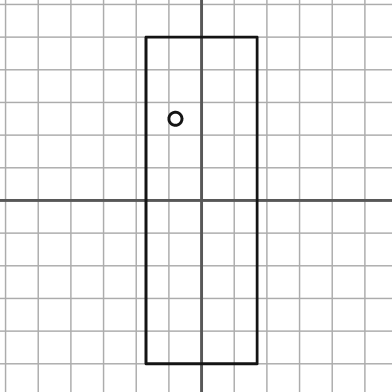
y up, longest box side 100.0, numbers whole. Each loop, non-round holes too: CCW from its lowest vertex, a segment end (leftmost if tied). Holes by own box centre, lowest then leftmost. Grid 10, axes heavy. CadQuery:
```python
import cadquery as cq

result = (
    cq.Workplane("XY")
    .moveTo(-17.0, -50.0)
    .lineTo(17.0, -50.0)
    .lineTo(17.0, 50.0)
    .lineTo(-17.0, 50.0)
    .close()
    .moveTo(-8.0, 25.0)
    .circle(2.0)
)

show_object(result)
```